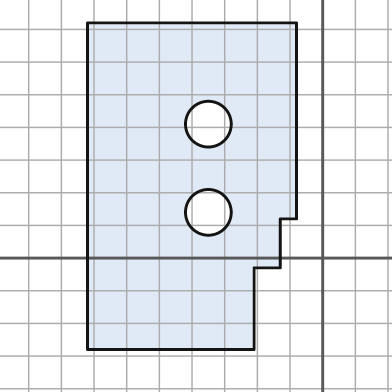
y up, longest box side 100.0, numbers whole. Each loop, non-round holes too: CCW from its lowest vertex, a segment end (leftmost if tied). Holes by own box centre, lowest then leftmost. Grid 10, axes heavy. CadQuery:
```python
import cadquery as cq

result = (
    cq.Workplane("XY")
    .moveTo(-72.0, -28.0)
    .lineTo(-21.0, -28.0)
    .lineTo(-21.0, -3.0)
    .lineTo(-13.0, -3.0)
    .lineTo(-13.0, 12.0)
    .lineTo(-8.0, 12.0)
    .lineTo(-8.0, 72.0)
    .lineTo(-72.0, 72.0)
    .close()
    .moveTo(-35.0, 14.0)
    .circle(7.0)
    .moveTo(-35.0, 41.0)
    .circle(7.0)
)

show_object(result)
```